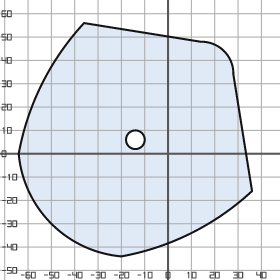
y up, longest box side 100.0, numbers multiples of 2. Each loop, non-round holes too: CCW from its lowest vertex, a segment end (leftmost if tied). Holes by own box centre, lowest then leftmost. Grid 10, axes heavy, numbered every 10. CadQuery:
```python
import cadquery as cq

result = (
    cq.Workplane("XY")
    .moveTo(-20.0, -44.0)
    .threePointArc((10.0, -34.0), (36.0, -16.0))
    .lineTo(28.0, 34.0)
    .threePointArc((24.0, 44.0), (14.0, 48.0))
    .lineTo(-36.0, 56.0)
    .threePointArc((-54.0, 30.0), (-64.0, 0.0))
    .threePointArc((-50.0, -30.0), (-20.0, -44.0))
    .close()
    .moveTo(-14.0, 6.0)
    .circle(4.0)
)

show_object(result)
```